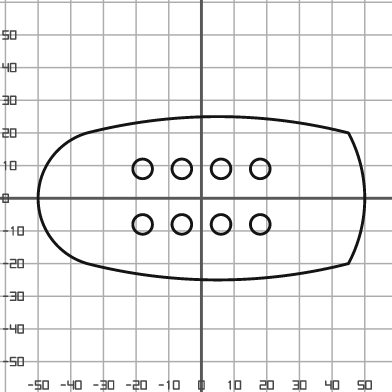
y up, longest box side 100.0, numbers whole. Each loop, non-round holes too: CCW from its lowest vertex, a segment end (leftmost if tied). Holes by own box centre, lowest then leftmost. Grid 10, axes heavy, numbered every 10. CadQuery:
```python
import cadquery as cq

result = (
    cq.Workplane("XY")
    .moveTo(-35.0, -20.0)
    .threePointArc((5.0, -25.0), (45.0, -20.0))
    .threePointArc((50.0, 0.0), (45.0, 20.0))
    .threePointArc((5.0, 25.0), (-35.0, 20.0))
    .threePointArc((-50.0, 0.0), (-35.0, -20.0))
    .close()
    .moveTo(-18.0, -8.0)
    .circle(3.0)
    .moveTo(-6.0, -8.0)
    .circle(3.0)
    .moveTo(6.0, -8.0)
    .circle(3.0)
    .moveTo(18.0, -8.0)
    .circle(3.0)
    .moveTo(-18.0, 9.0)
    .circle(3.0)
    .moveTo(-6.0, 9.0)
    .circle(3.0)
    .moveTo(6.0, 9.0)
    .circle(3.0)
    .moveTo(18.0, 9.0)
    .circle(3.0)
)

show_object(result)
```